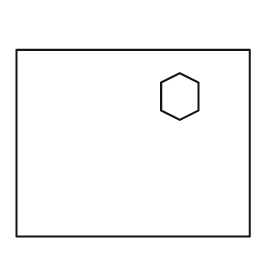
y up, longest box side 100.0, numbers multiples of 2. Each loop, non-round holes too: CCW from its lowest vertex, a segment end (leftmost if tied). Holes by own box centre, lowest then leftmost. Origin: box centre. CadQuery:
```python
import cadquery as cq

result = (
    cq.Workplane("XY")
    .moveTo(-50.0, -40.0)
    .lineTo(50.0, -40.0)
    .lineTo(50.0, 40.0)
    .lineTo(-50.0, 40.0)
    .close()
    .moveTo(20.0, 10.0)
    .lineTo(28.0, 14.0)
    .lineTo(28.0, 26.0)
    .lineTo(20.0, 30.0)
    .lineTo(12.0, 26.0)
    .lineTo(12.0, 14.0)
    .close()
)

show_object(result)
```